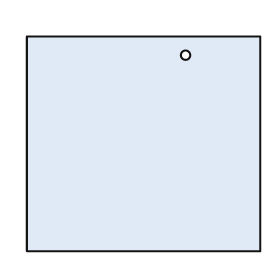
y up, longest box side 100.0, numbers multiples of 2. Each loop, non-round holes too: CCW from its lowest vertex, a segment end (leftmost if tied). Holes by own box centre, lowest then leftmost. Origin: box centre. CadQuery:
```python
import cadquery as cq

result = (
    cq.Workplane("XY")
    .moveTo(-50.0, -46.0)
    .lineTo(50.0, -46.0)
    .lineTo(50.0, 46.0)
    .lineTo(-50.0, 46.0)
    .close()
    .moveTo(18.0, 38.0)
    .circle(2.0)
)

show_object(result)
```